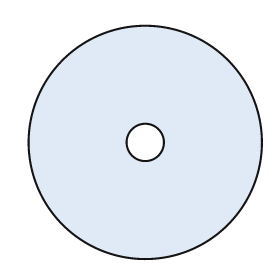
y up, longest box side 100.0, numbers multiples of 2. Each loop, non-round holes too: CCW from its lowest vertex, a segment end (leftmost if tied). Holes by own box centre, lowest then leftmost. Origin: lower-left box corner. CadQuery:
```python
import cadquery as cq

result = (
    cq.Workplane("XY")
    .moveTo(50.0, 50.0)
    .circle(50.0)
    .moveTo(50.0, 50.0)
    .circle(8.0)
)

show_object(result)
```